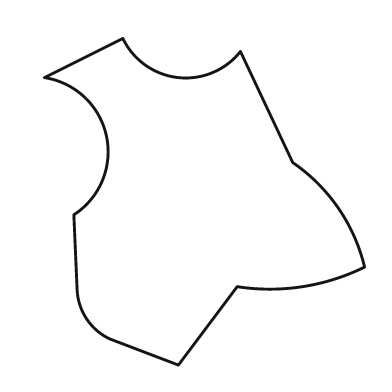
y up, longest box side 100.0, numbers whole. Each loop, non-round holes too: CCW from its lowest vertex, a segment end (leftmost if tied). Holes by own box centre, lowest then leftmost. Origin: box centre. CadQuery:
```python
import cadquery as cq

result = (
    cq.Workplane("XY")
    .moveTo(-8.0, -50.0)
    .lineTo(10.0, -26.0)
    .threePointArc((30.0, -26.0), (49.0, -20.0))
    .threePointArc((41.0, -2.0), (27.0, 12.0))
    .lineTo(11.0, 46.0)
    .threePointArc((-8.0, 38.0), (-25.0, 50.0))
    .lineTo(-49.0, 38.0)
    .threePointArc((-30.0, 20.0), (-40.0, -4.0))
    .lineTo(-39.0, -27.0)
    .threePointArc((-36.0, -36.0), (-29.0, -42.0))
    .close()
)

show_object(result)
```